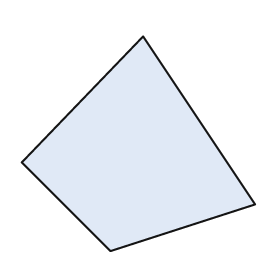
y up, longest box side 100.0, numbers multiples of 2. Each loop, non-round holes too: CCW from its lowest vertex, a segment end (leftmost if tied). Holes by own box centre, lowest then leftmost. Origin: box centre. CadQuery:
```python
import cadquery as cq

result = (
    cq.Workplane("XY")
    .moveTo(-12.0, -46.0)
    .lineTo(50.0, -26.0)
    .lineTo(2.0, 46.0)
    .lineTo(-50.0, -8.0)
    .close()
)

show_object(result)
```